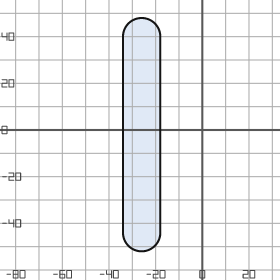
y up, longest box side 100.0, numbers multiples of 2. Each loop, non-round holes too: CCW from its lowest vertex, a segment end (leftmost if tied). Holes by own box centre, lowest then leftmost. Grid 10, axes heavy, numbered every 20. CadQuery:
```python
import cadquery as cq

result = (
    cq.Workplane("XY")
    .moveTo(-34.0, -44.0)
    .threePointArc((-26.0, -52.0), (-18.0, -44.0))
    .lineTo(-18.0, 40.0)
    .threePointArc((-26.0, 48.0), (-34.0, 40.0))
    .close()
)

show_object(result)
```